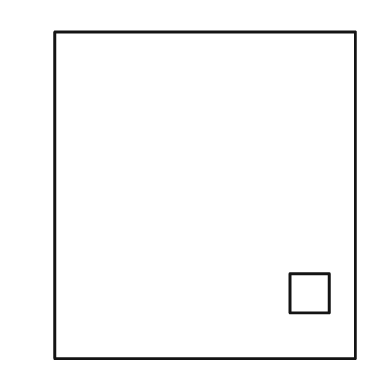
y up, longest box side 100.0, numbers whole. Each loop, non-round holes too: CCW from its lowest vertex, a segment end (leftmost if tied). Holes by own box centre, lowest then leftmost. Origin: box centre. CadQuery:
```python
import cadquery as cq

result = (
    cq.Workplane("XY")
    .moveTo(-46.0, -50.0)
    .lineTo(46.0, -50.0)
    .lineTo(46.0, 50.0)
    .lineTo(-46.0, 50.0)
    .close()
    .moveTo(26.0, -36.0)
    .lineTo(38.0, -36.0)
    .lineTo(38.0, -24.0)
    .lineTo(26.0, -24.0)
    .close()
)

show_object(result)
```